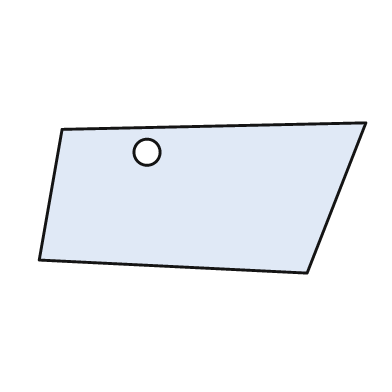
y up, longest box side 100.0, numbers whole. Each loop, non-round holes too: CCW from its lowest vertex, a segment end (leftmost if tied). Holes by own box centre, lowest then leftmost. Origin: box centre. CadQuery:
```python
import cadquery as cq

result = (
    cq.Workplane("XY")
    .moveTo(32.0, -23.0)
    .lineTo(50.0, 23.0)
    .lineTo(-43.0, 21.0)
    .lineTo(-50.0, -19.0)
    .close()
    .moveTo(-17.0, 14.0)
    .circle(4.0)
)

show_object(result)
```